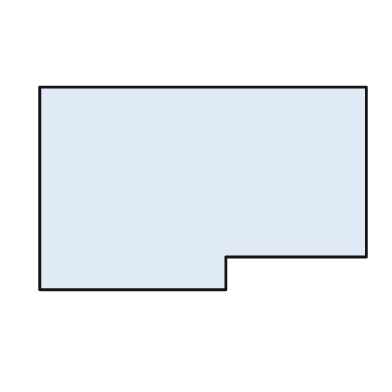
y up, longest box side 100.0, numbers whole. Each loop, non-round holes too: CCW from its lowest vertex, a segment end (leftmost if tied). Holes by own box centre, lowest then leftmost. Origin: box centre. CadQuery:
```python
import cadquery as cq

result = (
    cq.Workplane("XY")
    .moveTo(-50.0, -31.0)
    .lineTo(7.0, -31.0)
    .lineTo(7.0, -21.0)
    .lineTo(50.0, -21.0)
    .lineTo(50.0, 31.0)
    .lineTo(-50.0, 31.0)
    .close()
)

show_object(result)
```